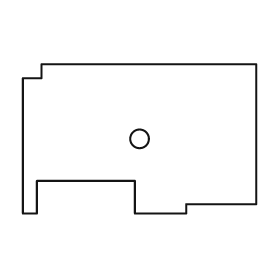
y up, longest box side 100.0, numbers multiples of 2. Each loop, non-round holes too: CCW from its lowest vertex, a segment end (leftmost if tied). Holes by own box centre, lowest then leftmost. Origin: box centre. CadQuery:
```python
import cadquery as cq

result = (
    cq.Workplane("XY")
    .moveTo(-50.0, -32.0)
    .lineTo(-44.0, -32.0)
    .lineTo(-44.0, -18.0)
    .lineTo(-2.0, -18.0)
    .lineTo(-2.0, -32.0)
    .lineTo(20.0, -32.0)
    .lineTo(20.0, -28.0)
    .lineTo(50.0, -28.0)
    .lineTo(50.0, 32.0)
    .lineTo(-42.0, 32.0)
    .lineTo(-42.0, 26.0)
    .lineTo(-50.0, 26.0)
    .close()
    .moveTo(0.0, 0.0)
    .circle(4.0)
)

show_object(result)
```